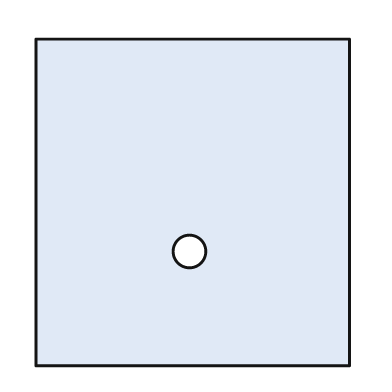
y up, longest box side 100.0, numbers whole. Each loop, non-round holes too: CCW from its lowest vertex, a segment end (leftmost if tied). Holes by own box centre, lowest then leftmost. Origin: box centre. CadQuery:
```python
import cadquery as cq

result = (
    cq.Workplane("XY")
    .moveTo(-48.0, -50.0)
    .lineTo(48.0, -50.0)
    .lineTo(48.0, 50.0)
    .lineTo(-48.0, 50.0)
    .close()
    .moveTo(-1.0, -15.0)
    .circle(5.0)
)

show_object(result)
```